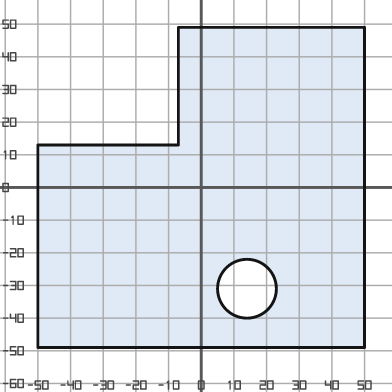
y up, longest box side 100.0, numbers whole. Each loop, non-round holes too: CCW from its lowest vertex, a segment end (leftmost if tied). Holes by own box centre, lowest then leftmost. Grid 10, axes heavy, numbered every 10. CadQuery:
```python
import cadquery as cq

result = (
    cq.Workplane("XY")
    .moveTo(-50.0, -49.0)
    .lineTo(50.0, -49.0)
    .lineTo(50.0, 49.0)
    .lineTo(-7.0, 49.0)
    .lineTo(-7.0, 13.0)
    .lineTo(-50.0, 13.0)
    .close()
    .moveTo(14.0, -31.0)
    .circle(9.0)
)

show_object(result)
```